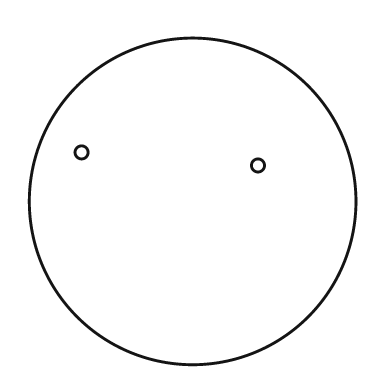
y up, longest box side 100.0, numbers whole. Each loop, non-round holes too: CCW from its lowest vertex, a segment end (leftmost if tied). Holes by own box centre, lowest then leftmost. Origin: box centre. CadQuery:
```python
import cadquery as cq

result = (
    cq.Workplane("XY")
    .moveTo(0.0, 0.0)
    .circle(50.0)
    .moveTo(20.0, 11.0)
    .circle(2.0)
    .moveTo(-34.0, 15.0)
    .circle(2.0)
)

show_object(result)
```